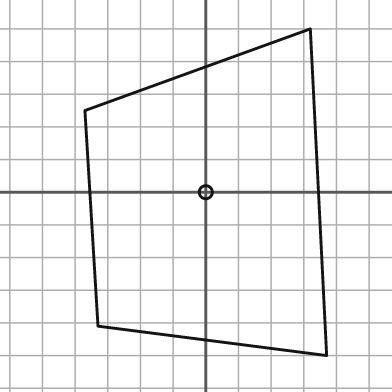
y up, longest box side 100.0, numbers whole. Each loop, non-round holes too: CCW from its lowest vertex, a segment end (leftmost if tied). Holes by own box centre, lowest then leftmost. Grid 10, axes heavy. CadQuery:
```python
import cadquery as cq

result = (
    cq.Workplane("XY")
    .moveTo(37.0, -50.0)
    .lineTo(32.0, 50.0)
    .lineTo(-37.0, 25.0)
    .lineTo(-33.0, -41.0)
    .close()
    .moveTo(0.0, 0.0)
    .circle(2.0)
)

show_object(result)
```